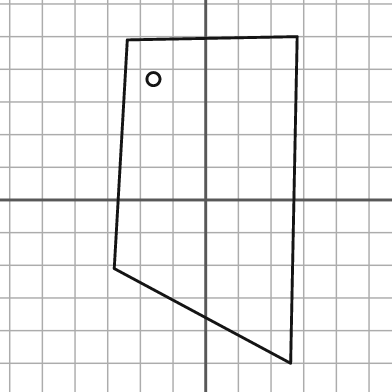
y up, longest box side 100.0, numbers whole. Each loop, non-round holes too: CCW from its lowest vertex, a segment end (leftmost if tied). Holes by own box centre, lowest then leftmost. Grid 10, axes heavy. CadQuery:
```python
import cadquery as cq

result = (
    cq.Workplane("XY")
    .moveTo(26.0, -50.0)
    .lineTo(28.0, 50.0)
    .lineTo(-24.0, 49.0)
    .lineTo(-28.0, -21.0)
    .close()
    .moveTo(-16.0, 37.0)
    .circle(2.0)
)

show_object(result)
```